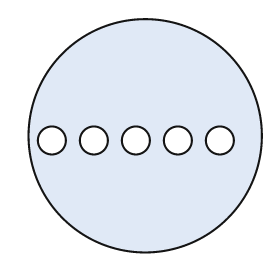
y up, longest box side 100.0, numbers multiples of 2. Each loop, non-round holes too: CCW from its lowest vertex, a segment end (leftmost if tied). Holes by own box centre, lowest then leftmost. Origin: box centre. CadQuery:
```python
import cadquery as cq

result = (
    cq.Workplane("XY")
    .moveTo(0.0, 0.0)
    .circle(50.0)
    .moveTo(-40.0, -2.0)
    .circle(6.0)
    .moveTo(-22.0, -2.0)
    .circle(6.0)
    .moveTo(-4.0, -2.0)
    .circle(6.0)
    .moveTo(14.0, -2.0)
    .circle(6.0)
    .moveTo(32.0, -2.0)
    .circle(6.0)
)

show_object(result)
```